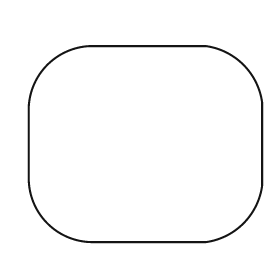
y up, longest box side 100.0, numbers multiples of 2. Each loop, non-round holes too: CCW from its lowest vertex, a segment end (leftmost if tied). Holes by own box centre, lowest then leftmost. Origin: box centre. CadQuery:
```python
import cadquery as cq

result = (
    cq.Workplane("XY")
    .moveTo(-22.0, -42.0)
    .lineTo(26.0, -42.0)
    .threePointArc((42.0, -34.0), (50.0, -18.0))
    .lineTo(50.0, 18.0)
    .threePointArc((42.0, 34.0), (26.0, 42.0))
    .lineTo(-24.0, 42.0)
    .threePointArc((-42.0, 34.0), (-50.0, 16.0))
    .lineTo(-50.0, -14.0)
    .threePointArc((-42.0, -34.0), (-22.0, -42.0))
    .close()
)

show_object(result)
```